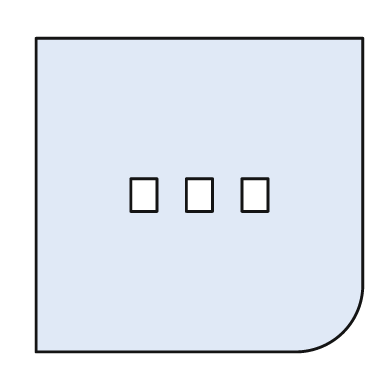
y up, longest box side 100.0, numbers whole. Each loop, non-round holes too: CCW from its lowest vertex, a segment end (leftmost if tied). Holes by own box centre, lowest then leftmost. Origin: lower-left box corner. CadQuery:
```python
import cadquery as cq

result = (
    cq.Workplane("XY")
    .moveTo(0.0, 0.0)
    .lineTo(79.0, 0.0)
    .threePointArc((94.0, 6.0), (100.0, 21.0))
    .lineTo(100.0, 96.0)
    .lineTo(0.0, 96.0)
    .close()
    .moveTo(29.0, 43.0)
    .lineTo(37.0, 43.0)
    .lineTo(37.0, 53.0)
    .lineTo(29.0, 53.0)
    .close()
    .moveTo(46.0, 43.0)
    .lineTo(54.0, 43.0)
    .lineTo(54.0, 53.0)
    .lineTo(46.0, 53.0)
    .close()
    .moveTo(63.0, 43.0)
    .lineTo(71.0, 43.0)
    .lineTo(71.0, 53.0)
    .lineTo(63.0, 53.0)
    .close()
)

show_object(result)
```